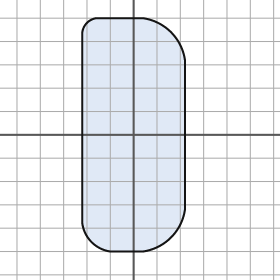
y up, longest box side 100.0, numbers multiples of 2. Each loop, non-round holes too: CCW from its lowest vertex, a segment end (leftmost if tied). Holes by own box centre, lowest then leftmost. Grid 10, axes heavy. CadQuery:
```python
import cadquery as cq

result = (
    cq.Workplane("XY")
    .moveTo(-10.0, -50.0)
    .lineTo(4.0, -50.0)
    .threePointArc((16.0, -44.0), (22.0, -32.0))
    .lineTo(22.0, 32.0)
    .threePointArc((16.0, 44.0), (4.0, 50.0))
    .lineTo(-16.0, 50.0)
    .threePointArc((-20.0, 48.0), (-22.0, 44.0))
    .lineTo(-22.0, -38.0)
    .threePointArc((-18.0, -46.0), (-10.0, -50.0))
    .close()
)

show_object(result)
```